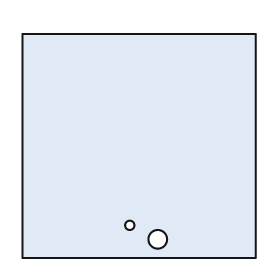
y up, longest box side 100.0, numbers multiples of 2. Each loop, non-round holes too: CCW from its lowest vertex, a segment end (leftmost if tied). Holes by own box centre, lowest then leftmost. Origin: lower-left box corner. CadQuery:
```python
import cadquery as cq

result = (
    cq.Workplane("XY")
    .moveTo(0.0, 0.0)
    .lineTo(100.0, 0.0)
    .lineTo(100.0, 96.0)
    .lineTo(0.0, 96.0)
    .close()
    .moveTo(58.0, 8.0)
    .circle(4.0)
    .moveTo(46.0, 14.0)
    .circle(2.0)
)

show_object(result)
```